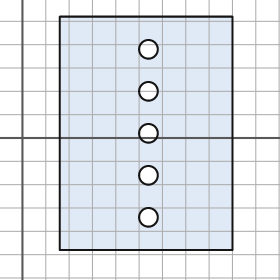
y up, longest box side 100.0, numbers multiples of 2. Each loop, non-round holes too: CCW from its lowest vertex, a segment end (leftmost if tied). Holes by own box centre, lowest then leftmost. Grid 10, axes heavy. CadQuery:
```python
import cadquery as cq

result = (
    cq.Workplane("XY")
    .moveTo(16.0, -48.0)
    .lineTo(90.0, -48.0)
    .lineTo(90.0, 52.0)
    .lineTo(16.0, 52.0)
    .close()
    .moveTo(54.0, -34.0)
    .circle(4.0)
    .moveTo(54.0, -16.0)
    .circle(4.0)
    .moveTo(54.0, 2.0)
    .circle(4.0)
    .moveTo(54.0, 20.0)
    .circle(4.0)
    .moveTo(54.0, 38.0)
    .circle(4.0)
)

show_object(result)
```